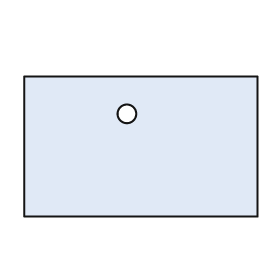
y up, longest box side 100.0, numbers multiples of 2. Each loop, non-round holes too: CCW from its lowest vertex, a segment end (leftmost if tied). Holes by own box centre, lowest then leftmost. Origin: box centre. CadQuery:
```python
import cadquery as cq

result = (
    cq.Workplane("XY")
    .moveTo(-50.0, -30.0)
    .lineTo(50.0, -30.0)
    .lineTo(50.0, 30.0)
    .lineTo(-50.0, 30.0)
    .close()
    .moveTo(-6.0, 14.0)
    .circle(4.0)
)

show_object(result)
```